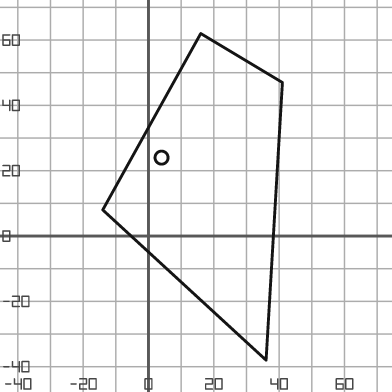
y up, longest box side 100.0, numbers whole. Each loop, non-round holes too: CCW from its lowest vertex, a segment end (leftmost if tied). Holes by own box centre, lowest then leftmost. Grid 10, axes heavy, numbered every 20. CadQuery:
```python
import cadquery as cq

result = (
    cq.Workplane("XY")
    .moveTo(36.0, -38.0)
    .lineTo(41.0, 47.0)
    .lineTo(16.0, 62.0)
    .lineTo(-14.0, 8.0)
    .close()
    .moveTo(4.0, 24.0)
    .circle(2.0)
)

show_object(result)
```